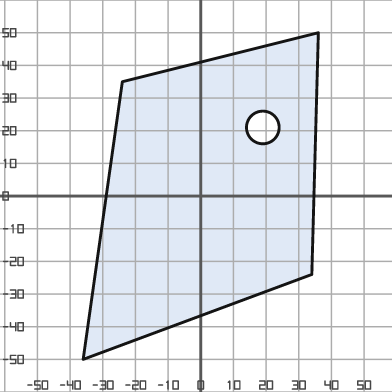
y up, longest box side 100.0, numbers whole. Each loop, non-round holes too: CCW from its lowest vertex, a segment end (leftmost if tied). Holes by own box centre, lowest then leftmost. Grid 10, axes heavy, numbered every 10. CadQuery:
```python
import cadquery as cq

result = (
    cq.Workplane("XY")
    .moveTo(-36.0, -50.0)
    .lineTo(34.0, -24.0)
    .lineTo(36.0, 50.0)
    .lineTo(-24.0, 35.0)
    .close()
    .moveTo(19.0, 21.0)
    .circle(5.0)
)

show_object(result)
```